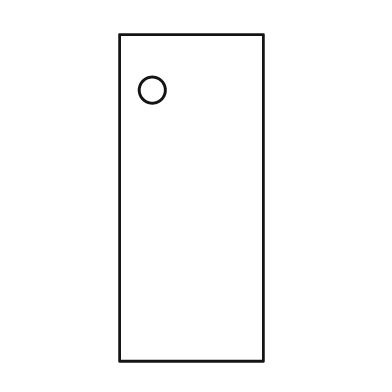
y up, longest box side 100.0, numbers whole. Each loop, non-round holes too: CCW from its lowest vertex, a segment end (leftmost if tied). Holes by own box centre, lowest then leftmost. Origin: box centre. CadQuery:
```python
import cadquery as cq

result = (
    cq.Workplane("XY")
    .moveTo(-22.0, -50.0)
    .lineTo(22.0, -50.0)
    .lineTo(22.0, 50.0)
    .lineTo(-22.0, 50.0)
    .close()
    .moveTo(-12.0, 33.0)
    .circle(4.0)
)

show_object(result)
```